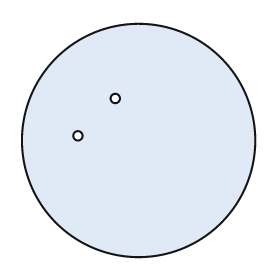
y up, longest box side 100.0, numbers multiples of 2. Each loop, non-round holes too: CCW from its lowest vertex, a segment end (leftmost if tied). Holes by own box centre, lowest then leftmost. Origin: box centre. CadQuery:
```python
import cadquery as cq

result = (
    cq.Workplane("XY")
    .moveTo(0.0, 0.0)
    .circle(50.0)
    .moveTo(-26.0, 2.0)
    .circle(2.0)
    .moveTo(-10.0, 18.0)
    .circle(2.0)
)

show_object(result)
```